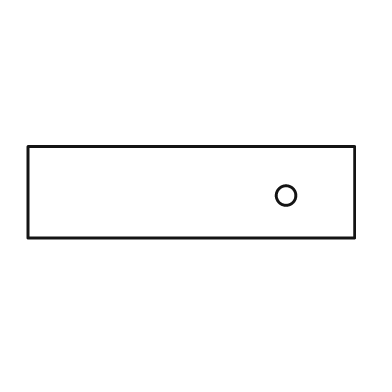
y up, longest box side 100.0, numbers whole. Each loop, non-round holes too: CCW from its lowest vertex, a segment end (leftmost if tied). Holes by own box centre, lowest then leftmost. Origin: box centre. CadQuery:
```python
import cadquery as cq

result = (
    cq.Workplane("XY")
    .moveTo(-50.0, -14.0)
    .lineTo(50.0, -14.0)
    .lineTo(50.0, 14.0)
    .lineTo(-50.0, 14.0)
    .close()
    .moveTo(29.0, -1.0)
    .circle(3.0)
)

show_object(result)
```